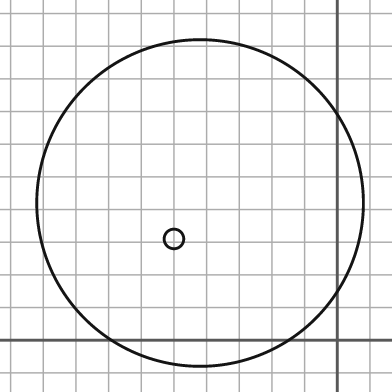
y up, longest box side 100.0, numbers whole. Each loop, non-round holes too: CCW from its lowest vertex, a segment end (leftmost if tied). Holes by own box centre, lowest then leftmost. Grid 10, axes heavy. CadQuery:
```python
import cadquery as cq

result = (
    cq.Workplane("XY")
    .moveTo(-42.0, 42.0)
    .circle(50.0)
    .moveTo(-50.0, 31.0)
    .circle(3.0)
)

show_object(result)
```